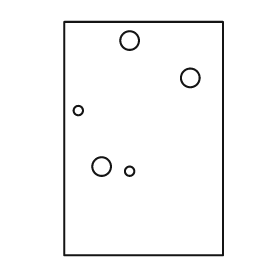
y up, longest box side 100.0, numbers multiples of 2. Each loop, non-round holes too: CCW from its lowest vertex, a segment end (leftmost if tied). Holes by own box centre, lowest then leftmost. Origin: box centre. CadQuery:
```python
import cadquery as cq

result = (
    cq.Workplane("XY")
    .moveTo(-34.0, -50.0)
    .lineTo(34.0, -50.0)
    .lineTo(34.0, 50.0)
    .lineTo(-34.0, 50.0)
    .close()
    .moveTo(-6.0, -14.0)
    .circle(2.0)
    .moveTo(-18.0, -12.0)
    .circle(4.0)
    .moveTo(-28.0, 12.0)
    .circle(2.0)
    .moveTo(20.0, 26.0)
    .circle(4.0)
    .moveTo(-6.0, 42.0)
    .circle(4.0)
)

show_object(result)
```